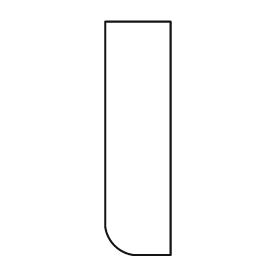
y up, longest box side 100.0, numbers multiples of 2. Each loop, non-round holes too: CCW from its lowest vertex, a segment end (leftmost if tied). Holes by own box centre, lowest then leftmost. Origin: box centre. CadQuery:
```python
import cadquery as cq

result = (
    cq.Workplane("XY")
    .moveTo(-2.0, -50.0)
    .lineTo(14.0, -50.0)
    .lineTo(14.0, 50.0)
    .lineTo(-14.0, 50.0)
    .lineTo(-14.0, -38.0)
    .threePointArc((-10.0, -46.0), (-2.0, -50.0))
    .close()
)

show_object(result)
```